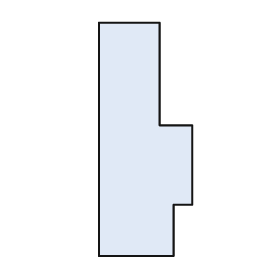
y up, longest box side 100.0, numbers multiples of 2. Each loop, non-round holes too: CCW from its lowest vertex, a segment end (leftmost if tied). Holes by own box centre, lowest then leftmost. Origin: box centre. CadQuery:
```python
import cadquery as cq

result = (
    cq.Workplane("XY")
    .moveTo(-20.0, -50.0)
    .lineTo(12.0, -50.0)
    .lineTo(12.0, -28.0)
    .lineTo(20.0, -28.0)
    .lineTo(20.0, 6.0)
    .lineTo(6.0, 6.0)
    .lineTo(6.0, 50.0)
    .lineTo(-20.0, 50.0)
    .close()
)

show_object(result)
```